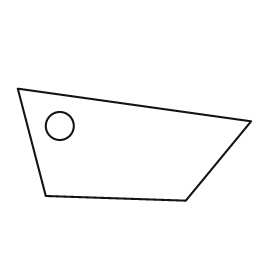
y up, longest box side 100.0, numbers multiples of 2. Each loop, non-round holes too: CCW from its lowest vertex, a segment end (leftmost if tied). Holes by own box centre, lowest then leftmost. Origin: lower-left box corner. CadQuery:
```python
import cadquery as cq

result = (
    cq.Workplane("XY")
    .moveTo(72.0, 0.0)
    .lineTo(100.0, 34.0)
    .lineTo(0.0, 48.0)
    .lineTo(12.0, 2.0)
    .close()
    .moveTo(18.0, 32.0)
    .circle(6.0)
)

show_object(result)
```